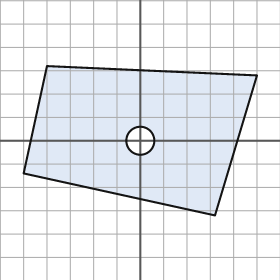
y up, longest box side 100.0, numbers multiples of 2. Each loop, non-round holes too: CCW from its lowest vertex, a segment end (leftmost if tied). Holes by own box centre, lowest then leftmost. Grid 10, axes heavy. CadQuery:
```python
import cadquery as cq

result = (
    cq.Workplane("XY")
    .moveTo(32.0, -32.0)
    .lineTo(50.0, 28.0)
    .lineTo(-40.0, 32.0)
    .lineTo(-50.0, -14.0)
    .close()
    .moveTo(0.0, 0.0)
    .circle(6.0)
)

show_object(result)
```